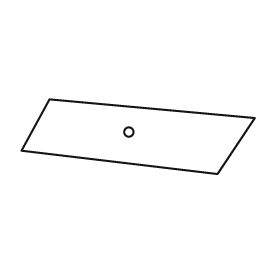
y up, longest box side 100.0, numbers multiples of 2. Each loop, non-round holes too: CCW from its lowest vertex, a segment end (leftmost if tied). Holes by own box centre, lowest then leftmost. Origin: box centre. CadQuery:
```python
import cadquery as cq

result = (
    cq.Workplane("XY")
    .moveTo(34.0, -16.0)
    .lineTo(50.0, 8.0)
    .lineTo(-38.0, 16.0)
    .lineTo(-50.0, -6.0)
    .close()
    .moveTo(-4.0, 2.0)
    .circle(2.0)
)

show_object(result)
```